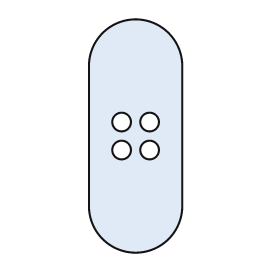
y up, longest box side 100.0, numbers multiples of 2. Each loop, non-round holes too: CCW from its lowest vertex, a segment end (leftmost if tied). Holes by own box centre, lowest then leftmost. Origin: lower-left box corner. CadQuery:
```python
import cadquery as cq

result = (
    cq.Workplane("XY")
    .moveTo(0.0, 20.0)
    .threePointArc((20.0, 0.0), (40.0, 20.0))
    .lineTo(40.0, 80.0)
    .threePointArc((20.0, 100.0), (0.0, 80.0))
    .close()
    .moveTo(14.0, 44.0)
    .circle(4.0)
    .moveTo(26.0, 44.0)
    .circle(4.0)
    .moveTo(14.0, 56.0)
    .circle(4.0)
    .moveTo(26.0, 56.0)
    .circle(4.0)
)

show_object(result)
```